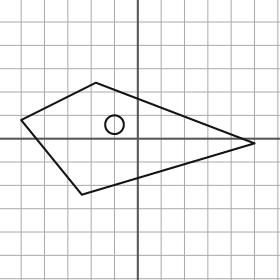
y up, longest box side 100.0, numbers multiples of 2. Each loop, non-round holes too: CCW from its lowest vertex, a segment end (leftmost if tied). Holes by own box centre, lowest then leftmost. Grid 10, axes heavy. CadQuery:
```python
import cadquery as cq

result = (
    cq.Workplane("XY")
    .moveTo(-24.0, -24.0)
    .lineTo(50.0, -2.0)
    .lineTo(-18.0, 24.0)
    .lineTo(-50.0, 8.0)
    .close()
    .moveTo(-10.0, 6.0)
    .circle(4.0)
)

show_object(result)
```